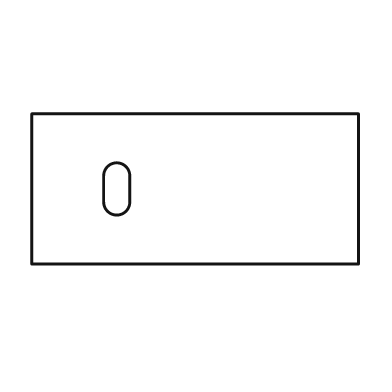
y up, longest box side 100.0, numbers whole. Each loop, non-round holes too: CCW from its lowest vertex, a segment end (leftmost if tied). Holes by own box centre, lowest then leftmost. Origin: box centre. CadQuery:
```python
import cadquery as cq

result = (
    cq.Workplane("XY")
    .moveTo(-50.0, -23.0)
    .lineTo(50.0, -23.0)
    .lineTo(50.0, 23.0)
    .lineTo(-50.0, 23.0)
    .close()
    .moveTo(-28.0, -4.0)
    .threePointArc((-24.0, -8.0), (-20.0, -4.0))
    .lineTo(-20.0, 4.0)
    .threePointArc((-24.0, 8.0), (-28.0, 4.0))
    .close()
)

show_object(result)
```